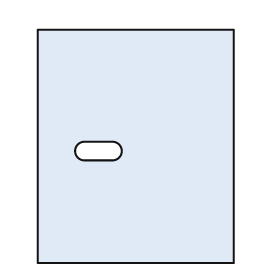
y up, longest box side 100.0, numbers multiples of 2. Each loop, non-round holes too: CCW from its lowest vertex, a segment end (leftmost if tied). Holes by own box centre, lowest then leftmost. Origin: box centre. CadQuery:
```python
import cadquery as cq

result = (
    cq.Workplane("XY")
    .moveTo(-42.0, -50.0)
    .lineTo(42.0, -50.0)
    .lineTo(42.0, 50.0)
    .lineTo(-42.0, 50.0)
    .close()
    .moveTo(-22.0, -6.0)
    .lineTo(-10.0, -6.0)
    .threePointArc((-6.0, -2.0), (-10.0, 2.0))
    .lineTo(-22.0, 2.0)
    .threePointArc((-26.0, -2.0), (-22.0, -6.0))
    .close()
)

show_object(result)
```